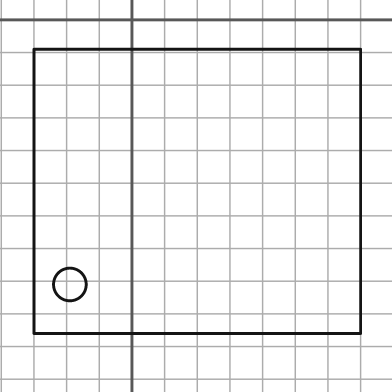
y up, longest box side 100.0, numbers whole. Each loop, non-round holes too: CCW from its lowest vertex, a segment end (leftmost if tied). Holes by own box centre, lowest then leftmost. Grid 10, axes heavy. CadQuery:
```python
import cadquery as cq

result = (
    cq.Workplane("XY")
    .moveTo(-30.0, -96.0)
    .lineTo(70.0, -96.0)
    .lineTo(70.0, -9.0)
    .lineTo(-30.0, -9.0)
    .close()
    .moveTo(-19.0, -81.0)
    .circle(5.0)
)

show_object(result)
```